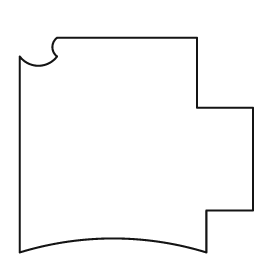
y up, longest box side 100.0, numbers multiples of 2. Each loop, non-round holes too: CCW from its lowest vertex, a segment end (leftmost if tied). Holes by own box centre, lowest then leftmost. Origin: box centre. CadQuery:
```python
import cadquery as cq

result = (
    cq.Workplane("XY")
    .moveTo(-50.0, -46.0)
    .threePointArc((-10.0, -40.0), (30.0, -46.0))
    .lineTo(30.0, -28.0)
    .lineTo(50.0, -28.0)
    .lineTo(50.0, 16.0)
    .lineTo(26.0, 16.0)
    .lineTo(26.0, 46.0)
    .lineTo(-34.0, 46.0)
    .threePointArc((-36.0, 42.0), (-34.0, 38.0))
    .threePointArc((-42.0, 34.0), (-50.0, 38.0))
    .close()
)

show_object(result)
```